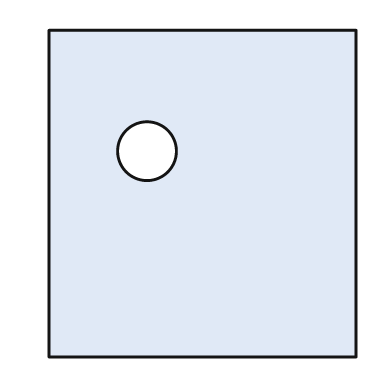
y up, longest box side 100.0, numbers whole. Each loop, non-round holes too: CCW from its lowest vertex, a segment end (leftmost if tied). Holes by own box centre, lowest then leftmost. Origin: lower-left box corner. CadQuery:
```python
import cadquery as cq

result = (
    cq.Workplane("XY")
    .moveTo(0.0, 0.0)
    .lineTo(94.0, 0.0)
    .lineTo(94.0, 100.0)
    .lineTo(0.0, 100.0)
    .close()
    .moveTo(30.0, 63.0)
    .circle(9.0)
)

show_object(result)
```